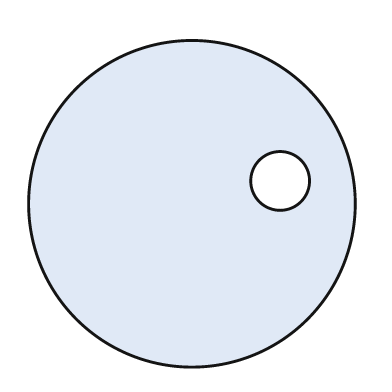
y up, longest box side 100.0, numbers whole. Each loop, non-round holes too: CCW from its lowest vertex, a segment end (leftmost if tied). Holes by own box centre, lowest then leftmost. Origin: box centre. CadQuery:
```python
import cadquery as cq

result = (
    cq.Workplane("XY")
    .moveTo(0.0, 0.0)
    .circle(50.0)
    .moveTo(27.0, 7.0)
    .circle(9.0)
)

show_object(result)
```